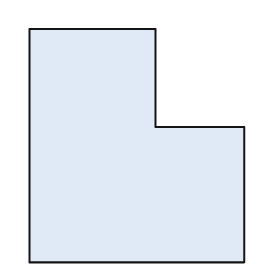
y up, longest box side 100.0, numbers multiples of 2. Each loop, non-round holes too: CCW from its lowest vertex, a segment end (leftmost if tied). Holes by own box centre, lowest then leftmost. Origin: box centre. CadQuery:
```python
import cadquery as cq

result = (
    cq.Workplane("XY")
    .moveTo(-46.0, -50.0)
    .lineTo(46.0, -50.0)
    .lineTo(46.0, 8.0)
    .lineTo(8.0, 8.0)
    .lineTo(8.0, 50.0)
    .lineTo(-46.0, 50.0)
    .close()
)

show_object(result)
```